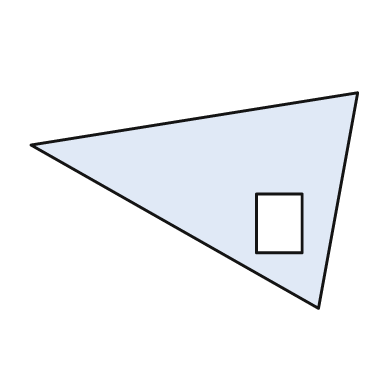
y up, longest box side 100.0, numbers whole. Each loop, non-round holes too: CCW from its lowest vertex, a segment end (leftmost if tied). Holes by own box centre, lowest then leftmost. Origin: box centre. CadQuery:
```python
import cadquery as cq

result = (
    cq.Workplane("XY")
    .moveTo(38.0, -33.0)
    .lineTo(50.0, 33.0)
    .lineTo(-50.0, 17.0)
    .close()
    .moveTo(19.0, -16.0)
    .lineTo(33.0, -16.0)
    .lineTo(33.0, 2.0)
    .lineTo(19.0, 2.0)
    .close()
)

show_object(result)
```